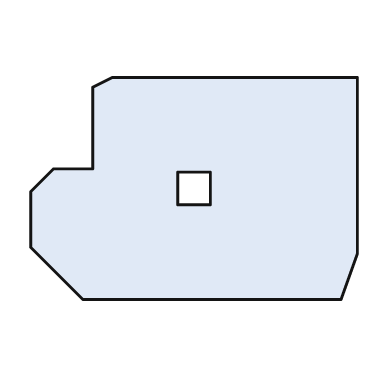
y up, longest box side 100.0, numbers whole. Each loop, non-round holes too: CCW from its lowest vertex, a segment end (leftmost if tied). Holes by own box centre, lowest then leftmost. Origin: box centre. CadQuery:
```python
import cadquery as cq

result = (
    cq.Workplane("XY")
    .moveTo(-34.0, -34.0)
    .lineTo(45.0, -34.0)
    .lineTo(50.0, -20.0)
    .lineTo(50.0, 34.0)
    .lineTo(-25.0, 34.0)
    .lineTo(-31.0, 31.0)
    .lineTo(-31.0, 6.0)
    .lineTo(-43.0, 6.0)
    .lineTo(-50.0, -1.0)
    .lineTo(-50.0, -18.0)
    .close()
    .moveTo(-5.0, -5.0)
    .lineTo(5.0, -5.0)
    .lineTo(5.0, 5.0)
    .lineTo(-5.0, 5.0)
    .close()
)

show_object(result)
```